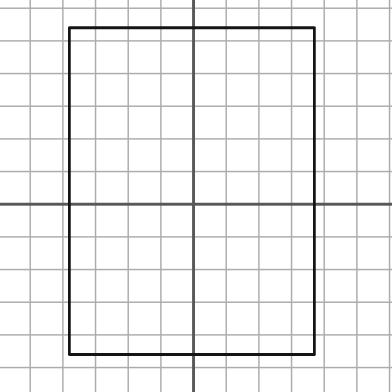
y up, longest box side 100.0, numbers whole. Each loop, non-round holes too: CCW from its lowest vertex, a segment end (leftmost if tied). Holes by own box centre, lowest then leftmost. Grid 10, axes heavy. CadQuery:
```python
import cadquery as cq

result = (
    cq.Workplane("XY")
    .moveTo(-38.0, -46.0)
    .lineTo(37.0, -46.0)
    .lineTo(37.0, 54.0)
    .lineTo(-38.0, 54.0)
    .close()
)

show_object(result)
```